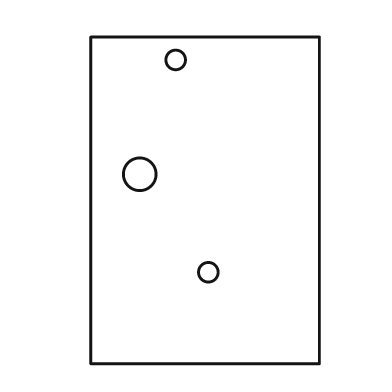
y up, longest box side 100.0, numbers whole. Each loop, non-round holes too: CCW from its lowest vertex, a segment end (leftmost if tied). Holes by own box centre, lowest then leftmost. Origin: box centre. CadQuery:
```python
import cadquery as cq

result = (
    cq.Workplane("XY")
    .moveTo(-35.0, -50.0)
    .lineTo(35.0, -50.0)
    .lineTo(35.0, 50.0)
    .lineTo(-35.0, 50.0)
    .close()
    .moveTo(1.0, -22.0)
    .circle(3.0)
    .moveTo(-20.0, 8.0)
    .circle(5.0)
    .moveTo(-9.0, 43.0)
    .circle(3.0)
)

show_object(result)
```